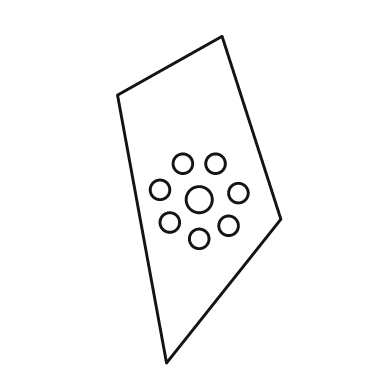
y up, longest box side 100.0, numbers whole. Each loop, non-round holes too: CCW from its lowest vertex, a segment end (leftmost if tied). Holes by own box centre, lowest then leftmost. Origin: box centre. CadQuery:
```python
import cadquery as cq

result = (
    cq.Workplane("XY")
    .moveTo(-10.0, -50.0)
    .lineTo(25.0, -6.0)
    .lineTo(7.0, 50.0)
    .lineTo(-25.0, 32.0)
    .close()
    .moveTo(0.0, -12.0)
    .circle(3.0)
    .moveTo(9.0, -8.0)
    .circle(3.0)
    .moveTo(-9.0, -7.0)
    .circle(3.0)
    .moveTo(0.0, 0.0)
    .circle(4.0)
    .moveTo(12.0, 2.0)
    .circle(3.0)
    .moveTo(-12.0, 3.0)
    .circle(3.0)
    .moveTo(-5.0, 11.0)
    .circle(3.0)
    .moveTo(5.0, 11.0)
    .circle(3.0)
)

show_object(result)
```